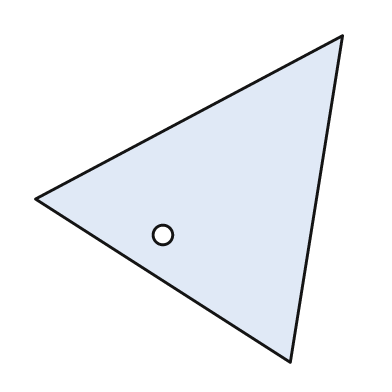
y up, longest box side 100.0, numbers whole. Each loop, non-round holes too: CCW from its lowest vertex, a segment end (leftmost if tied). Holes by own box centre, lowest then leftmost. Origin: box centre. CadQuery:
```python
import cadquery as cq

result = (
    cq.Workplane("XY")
    .moveTo(31.0, -50.0)
    .lineTo(47.0, 50.0)
    .lineTo(-47.0, 0.0)
    .close()
    .moveTo(-8.0, -11.0)
    .circle(3.0)
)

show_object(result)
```